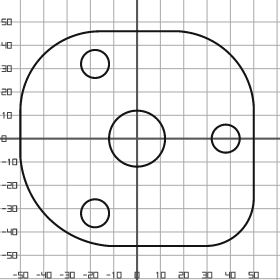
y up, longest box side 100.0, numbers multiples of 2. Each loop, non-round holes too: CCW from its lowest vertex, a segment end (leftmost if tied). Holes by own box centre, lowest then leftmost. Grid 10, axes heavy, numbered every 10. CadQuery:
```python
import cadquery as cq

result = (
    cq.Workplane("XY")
    .moveTo(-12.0, -46.0)
    .lineTo(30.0, -46.0)
    .threePointArc((44.0, -40.0), (50.0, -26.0))
    .lineTo(50.0, 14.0)
    .threePointArc((40.0, 36.0), (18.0, 46.0))
    .lineTo(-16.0, 46.0)
    .threePointArc((-40.0, 36.0), (-50.0, 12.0))
    .lineTo(-50.0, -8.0)
    .threePointArc((-38.0, -34.0), (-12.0, -46.0))
    .close()
    .moveTo(-18.0, -32.0)
    .circle(6.0)
    .moveTo(0.0, 0.0)
    .circle(12.0)
    .moveTo(38.0, 0.0)
    .circle(6.0)
    .moveTo(-18.0, 32.0)
    .circle(6.0)
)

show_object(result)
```